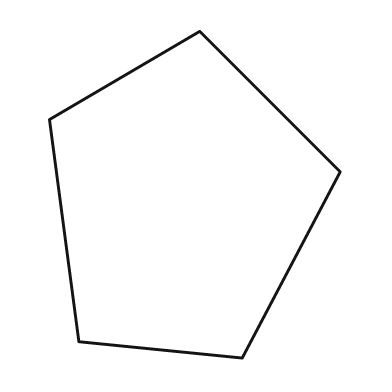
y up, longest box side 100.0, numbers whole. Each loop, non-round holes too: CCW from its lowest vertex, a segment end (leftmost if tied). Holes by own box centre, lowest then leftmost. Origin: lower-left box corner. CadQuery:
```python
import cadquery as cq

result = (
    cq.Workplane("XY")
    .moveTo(59.0, 0.0)
    .lineTo(89.0, 57.0)
    .lineTo(46.0, 100.0)
    .lineTo(0.0, 73.0)
    .lineTo(9.0, 5.0)
    .close()
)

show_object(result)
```